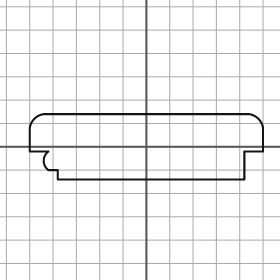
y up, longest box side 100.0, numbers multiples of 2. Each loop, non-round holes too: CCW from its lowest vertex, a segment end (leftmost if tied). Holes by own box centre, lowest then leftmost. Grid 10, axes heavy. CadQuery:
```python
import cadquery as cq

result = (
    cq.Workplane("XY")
    .moveTo(-38.0, -14.0)
    .lineTo(42.0, -14.0)
    .lineTo(42.0, -2.0)
    .lineTo(50.0, -2.0)
    .lineTo(50.0, 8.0)
    .threePointArc((48.0, 12.0), (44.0, 14.0))
    .lineTo(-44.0, 14.0)
    .threePointArc((-48.0, 12.0), (-50.0, 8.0))
    .lineTo(-50.0, -2.0)
    .lineTo(-42.0, -2.0)
    .threePointArc((-44.0, -6.0), (-42.0, -10.0))
    .lineTo(-38.0, -10.0)
    .close()
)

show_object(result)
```